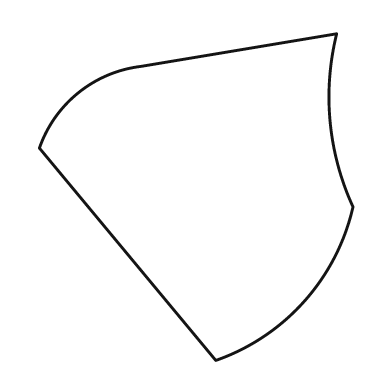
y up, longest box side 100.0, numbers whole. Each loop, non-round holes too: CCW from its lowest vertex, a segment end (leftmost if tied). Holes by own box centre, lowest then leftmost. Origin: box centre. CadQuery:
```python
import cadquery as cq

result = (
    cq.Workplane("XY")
    .moveTo(6.0, -50.0)
    .threePointArc((33.0, -32.0), (48.0, -3.0))
    .threePointArc((41.0, 23.0), (43.0, 50.0))
    .lineTo(-17.0, 40.0)
    .threePointArc((-36.0, 32.0), (-48.0, 15.0))
    .close()
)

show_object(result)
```